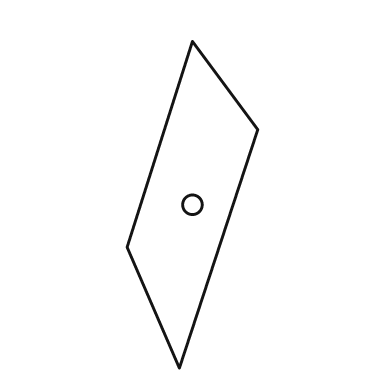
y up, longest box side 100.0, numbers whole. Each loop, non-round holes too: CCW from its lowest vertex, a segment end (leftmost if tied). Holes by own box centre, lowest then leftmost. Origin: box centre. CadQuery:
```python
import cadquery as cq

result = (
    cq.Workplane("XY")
    .moveTo(-4.0, -50.0)
    .lineTo(20.0, 23.0)
    .lineTo(0.0, 50.0)
    .lineTo(-20.0, -13.0)
    .close()
    .moveTo(0.0, 0.0)
    .circle(3.0)
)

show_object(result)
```